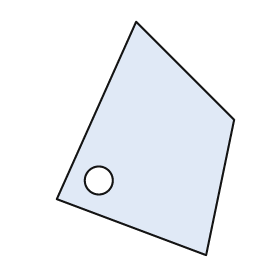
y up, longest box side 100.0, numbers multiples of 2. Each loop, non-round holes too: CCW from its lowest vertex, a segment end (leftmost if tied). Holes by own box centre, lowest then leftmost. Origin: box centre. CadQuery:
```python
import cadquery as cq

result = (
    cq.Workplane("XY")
    .moveTo(26.0, -50.0)
    .lineTo(38.0, 8.0)
    .lineTo(-4.0, 50.0)
    .lineTo(-38.0, -26.0)
    .close()
    .moveTo(-20.0, -18.0)
    .circle(6.0)
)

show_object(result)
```